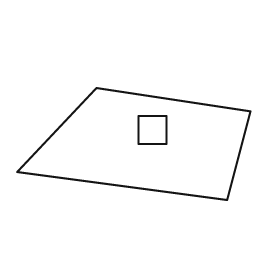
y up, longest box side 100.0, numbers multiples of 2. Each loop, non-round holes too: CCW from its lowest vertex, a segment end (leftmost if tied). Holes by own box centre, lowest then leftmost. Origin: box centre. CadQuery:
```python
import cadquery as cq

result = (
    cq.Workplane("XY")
    .moveTo(40.0, -24.0)
    .lineTo(50.0, 14.0)
    .lineTo(-16.0, 24.0)
    .lineTo(-50.0, -12.0)
    .close()
    .moveTo(2.0, 0.0)
    .lineTo(14.0, 0.0)
    .lineTo(14.0, 12.0)
    .lineTo(2.0, 12.0)
    .close()
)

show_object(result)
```